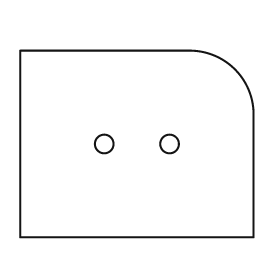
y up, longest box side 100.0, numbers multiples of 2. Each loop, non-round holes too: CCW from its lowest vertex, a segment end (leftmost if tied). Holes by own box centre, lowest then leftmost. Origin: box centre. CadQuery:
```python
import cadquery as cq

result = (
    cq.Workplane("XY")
    .moveTo(-50.0, -40.0)
    .lineTo(50.0, -40.0)
    .lineTo(50.0, 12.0)
    .threePointArc((42.0, 32.0), (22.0, 40.0))
    .lineTo(-50.0, 40.0)
    .close()
    .moveTo(-14.0, 0.0)
    .circle(4.0)
    .moveTo(14.0, 0.0)
    .circle(4.0)
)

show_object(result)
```